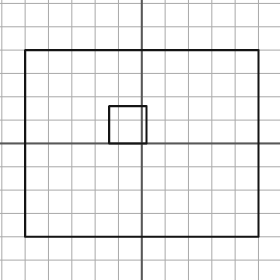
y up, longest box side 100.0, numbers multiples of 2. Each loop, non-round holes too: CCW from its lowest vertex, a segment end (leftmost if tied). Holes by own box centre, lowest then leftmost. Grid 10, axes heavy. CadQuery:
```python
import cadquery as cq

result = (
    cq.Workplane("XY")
    .moveTo(-50.0, -40.0)
    .lineTo(50.0, -40.0)
    .lineTo(50.0, 40.0)
    .lineTo(-50.0, 40.0)
    .close()
    .moveTo(-14.0, 0.0)
    .lineTo(2.0, 0.0)
    .lineTo(2.0, 16.0)
    .lineTo(-14.0, 16.0)
    .close()
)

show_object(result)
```